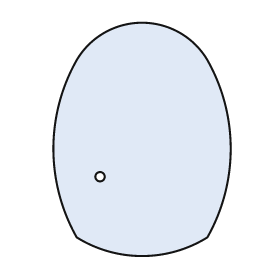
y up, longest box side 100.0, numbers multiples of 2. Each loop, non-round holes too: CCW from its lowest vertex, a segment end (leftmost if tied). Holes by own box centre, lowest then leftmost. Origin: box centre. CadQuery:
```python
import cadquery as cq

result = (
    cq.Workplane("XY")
    .moveTo(-28.0, -42.0)
    .threePointArc((0.0, -50.0), (28.0, -42.0))
    .threePointArc((38.0, -4.0), (28.0, 34.0))
    .threePointArc((0.0, 50.0), (-28.0, 34.0))
    .threePointArc((-38.0, -4.0), (-28.0, -42.0))
    .close()
    .moveTo(-18.0, -16.0)
    .circle(2.0)
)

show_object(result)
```